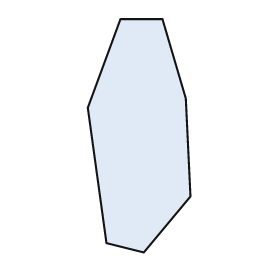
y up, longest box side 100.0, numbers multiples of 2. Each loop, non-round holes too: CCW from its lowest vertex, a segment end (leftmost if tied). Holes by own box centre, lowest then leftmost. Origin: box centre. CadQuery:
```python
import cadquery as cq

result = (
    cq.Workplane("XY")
    .moveTo(2.0, -50.0)
    .lineTo(22.0, -26.0)
    .lineTo(20.0, 16.0)
    .lineTo(10.0, 50.0)
    .lineTo(-8.0, 50.0)
    .lineTo(-22.0, 12.0)
    .lineTo(-14.0, -46.0)
    .close()
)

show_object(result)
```